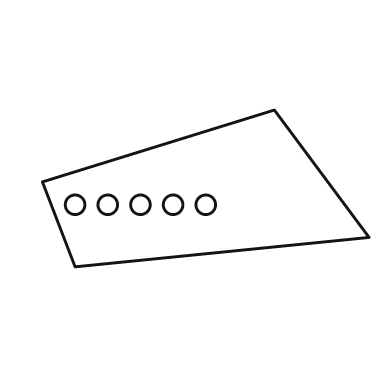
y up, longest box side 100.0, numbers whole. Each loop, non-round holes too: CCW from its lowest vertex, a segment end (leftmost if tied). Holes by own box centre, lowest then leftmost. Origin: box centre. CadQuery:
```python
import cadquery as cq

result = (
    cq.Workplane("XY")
    .moveTo(-40.0, -24.0)
    .lineTo(50.0, -15.0)
    .lineTo(21.0, 24.0)
    .lineTo(-50.0, 2.0)
    .close()
    .moveTo(-40.0, -5.0)
    .circle(3.0)
    .moveTo(-30.0, -5.0)
    .circle(3.0)
    .moveTo(-20.0, -5.0)
    .circle(3.0)
    .moveTo(-10.0, -5.0)
    .circle(3.0)
    .moveTo(0.0, -5.0)
    .circle(3.0)
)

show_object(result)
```